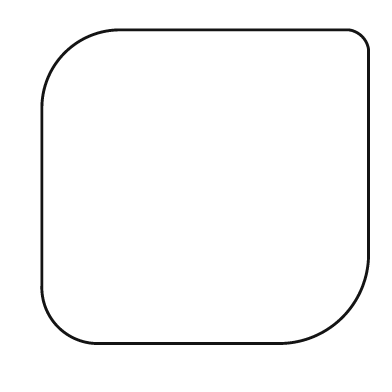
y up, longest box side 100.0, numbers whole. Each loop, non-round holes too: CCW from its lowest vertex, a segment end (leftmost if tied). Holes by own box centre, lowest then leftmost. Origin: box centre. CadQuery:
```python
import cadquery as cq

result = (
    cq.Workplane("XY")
    .moveTo(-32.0, -48.0)
    .lineTo(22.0, -48.0)
    .threePointArc((42.0, -40.0), (50.0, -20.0))
    .lineTo(50.0, 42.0)
    .threePointArc((48.0, 46.0), (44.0, 48.0))
    .lineTo(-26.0, 48.0)
    .threePointArc((-43.0, 41.0), (-50.0, 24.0))
    .lineTo(-50.0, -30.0)
    .threePointArc((-45.0, -43.0), (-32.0, -48.0))
    .close()
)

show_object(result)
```